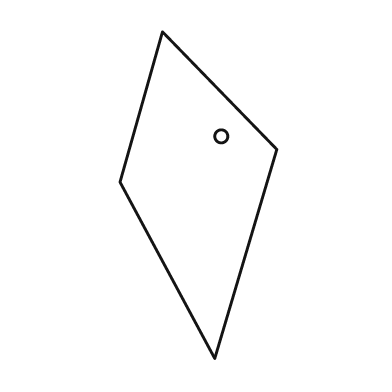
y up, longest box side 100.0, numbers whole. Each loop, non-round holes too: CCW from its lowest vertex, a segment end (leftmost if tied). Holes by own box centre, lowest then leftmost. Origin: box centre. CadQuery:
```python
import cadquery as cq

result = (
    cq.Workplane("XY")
    .moveTo(5.0, -50.0)
    .lineTo(24.0, 14.0)
    .lineTo(-11.0, 50.0)
    .lineTo(-24.0, 4.0)
    .close()
    .moveTo(7.0, 18.0)
    .circle(2.0)
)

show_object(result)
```